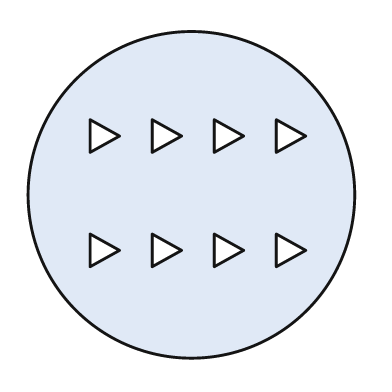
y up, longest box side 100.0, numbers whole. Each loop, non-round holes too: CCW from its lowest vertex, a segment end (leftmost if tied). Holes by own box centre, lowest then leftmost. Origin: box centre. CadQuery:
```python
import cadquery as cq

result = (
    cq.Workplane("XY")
    .moveTo(0.0, 0.0)
    .circle(50.0)
    .moveTo(-31.0, -22.0)
    .lineTo(-22.0, -17.0)
    .lineTo(-31.0, -12.0)
    .close()
    .moveTo(-12.0, -22.0)
    .lineTo(-3.0, -17.0)
    .lineTo(-12.0, -12.0)
    .close()
    .moveTo(7.0, -22.0)
    .lineTo(16.0, -17.0)
    .lineTo(7.0, -12.0)
    .close()
    .moveTo(26.0, -22.0)
    .lineTo(35.0, -17.0)
    .lineTo(26.0, -12.0)
    .close()
    .moveTo(-31.0, 13.0)
    .lineTo(-22.0, 18.0)
    .lineTo(-31.0, 23.0)
    .close()
    .moveTo(-12.0, 13.0)
    .lineTo(-3.0, 18.0)
    .lineTo(-12.0, 23.0)
    .close()
    .moveTo(7.0, 13.0)
    .lineTo(16.0, 18.0)
    .lineTo(7.0, 23.0)
    .close()
    .moveTo(26.0, 13.0)
    .lineTo(35.0, 18.0)
    .lineTo(26.0, 23.0)
    .close()
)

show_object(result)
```